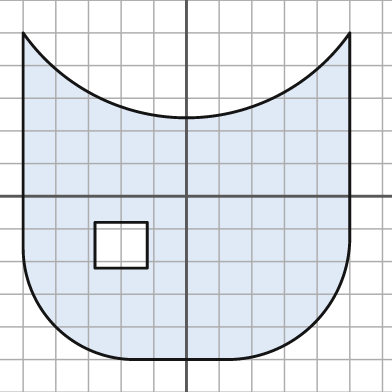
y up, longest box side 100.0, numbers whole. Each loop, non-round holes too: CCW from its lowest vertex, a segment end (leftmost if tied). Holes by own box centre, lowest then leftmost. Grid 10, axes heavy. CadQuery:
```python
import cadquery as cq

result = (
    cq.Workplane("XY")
    .moveTo(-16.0, -50.0)
    .lineTo(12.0, -50.0)
    .threePointArc((39.0, -39.0), (50.0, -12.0))
    .lineTo(50.0, 50.0)
    .threePointArc((0.0, 24.0), (-50.0, 50.0))
    .lineTo(-50.0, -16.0)
    .threePointArc((-40.0, -40.0), (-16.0, -50.0))
    .close()
    .moveTo(-28.0, -22.0)
    .lineTo(-12.0, -22.0)
    .lineTo(-12.0, -8.0)
    .lineTo(-28.0, -8.0)
    .close()
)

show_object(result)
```